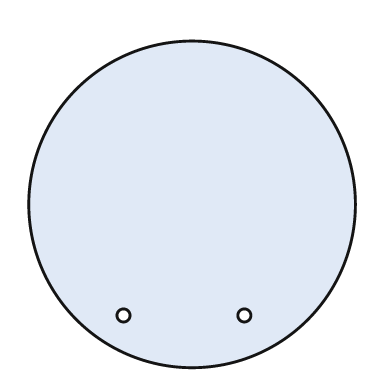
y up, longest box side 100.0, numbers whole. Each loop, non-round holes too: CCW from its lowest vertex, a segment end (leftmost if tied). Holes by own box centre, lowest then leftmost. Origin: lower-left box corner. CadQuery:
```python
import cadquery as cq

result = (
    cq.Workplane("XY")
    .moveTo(50.0, 50.0)
    .circle(50.0)
    .moveTo(29.0, 16.0)
    .circle(2.0)
    .moveTo(66.0, 16.0)
    .circle(2.0)
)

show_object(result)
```